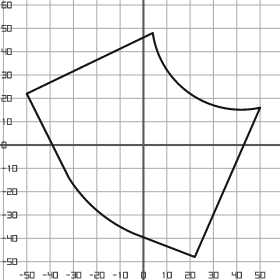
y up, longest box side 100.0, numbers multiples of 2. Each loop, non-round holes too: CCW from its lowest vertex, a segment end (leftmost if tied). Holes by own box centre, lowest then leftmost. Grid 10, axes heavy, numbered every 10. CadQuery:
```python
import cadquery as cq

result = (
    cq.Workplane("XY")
    .moveTo(22.0, -48.0)
    .lineTo(50.0, 16.0)
    .threePointArc((20.0, 22.0), (4.0, 48.0))
    .lineTo(-50.0, 22.0)
    .lineTo(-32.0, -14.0)
    .threePointArc((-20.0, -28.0), (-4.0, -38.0))
    .close()
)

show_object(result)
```